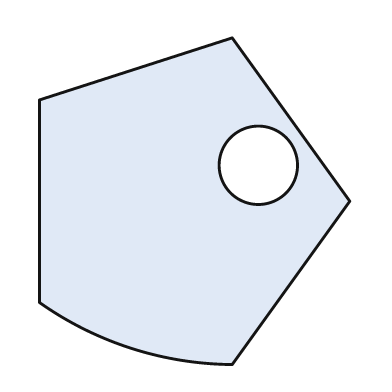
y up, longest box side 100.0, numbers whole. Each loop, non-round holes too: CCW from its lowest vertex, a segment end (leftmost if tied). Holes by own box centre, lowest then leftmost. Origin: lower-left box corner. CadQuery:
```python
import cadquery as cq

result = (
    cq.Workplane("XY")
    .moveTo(59.0, 0.0)
    .lineTo(95.0, 50.0)
    .lineTo(59.0, 100.0)
    .lineTo(0.0, 81.0)
    .lineTo(0.0, 19.0)
    .threePointArc((28.0, 5.0), (59.0, 0.0))
    .close()
    .moveTo(67.0, 61.0)
    .circle(12.0)
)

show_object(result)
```